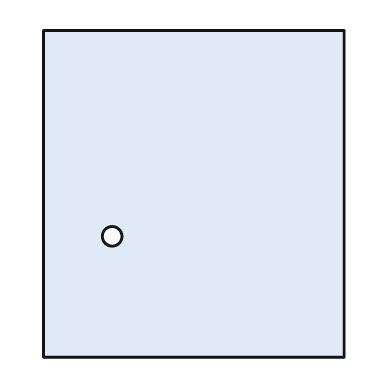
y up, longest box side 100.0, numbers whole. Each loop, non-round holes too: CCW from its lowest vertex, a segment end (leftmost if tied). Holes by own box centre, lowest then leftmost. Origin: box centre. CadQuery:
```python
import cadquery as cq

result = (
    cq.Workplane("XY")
    .moveTo(-46.0, -50.0)
    .lineTo(46.0, -50.0)
    .lineTo(46.0, 50.0)
    .lineTo(-46.0, 50.0)
    .close()
    .moveTo(-25.0, -13.0)
    .circle(3.0)
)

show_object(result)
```